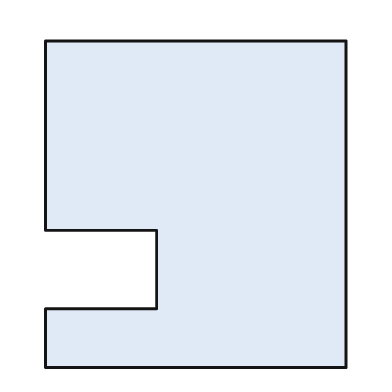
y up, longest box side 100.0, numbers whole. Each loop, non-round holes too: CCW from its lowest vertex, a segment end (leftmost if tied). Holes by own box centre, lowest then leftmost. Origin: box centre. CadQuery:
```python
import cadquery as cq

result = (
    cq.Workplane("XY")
    .moveTo(-46.0, -50.0)
    .lineTo(46.0, -50.0)
    .lineTo(46.0, 50.0)
    .lineTo(-46.0, 50.0)
    .lineTo(-46.0, -8.0)
    .lineTo(-12.0, -8.0)
    .lineTo(-12.0, -32.0)
    .lineTo(-46.0, -32.0)
    .close()
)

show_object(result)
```